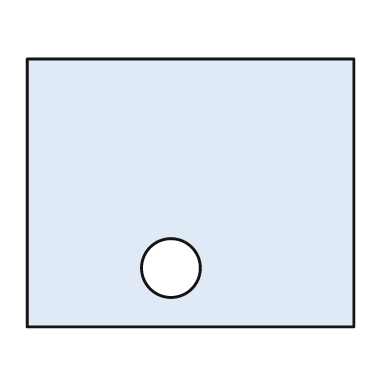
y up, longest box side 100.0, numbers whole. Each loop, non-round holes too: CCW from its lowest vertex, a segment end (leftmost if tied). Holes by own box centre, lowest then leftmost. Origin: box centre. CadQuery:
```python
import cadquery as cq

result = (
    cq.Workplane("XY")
    .moveTo(-50.0, -41.0)
    .lineTo(50.0, -41.0)
    .lineTo(50.0, 41.0)
    .lineTo(-50.0, 41.0)
    .close()
    .moveTo(-6.0, -23.0)
    .circle(9.0)
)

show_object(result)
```